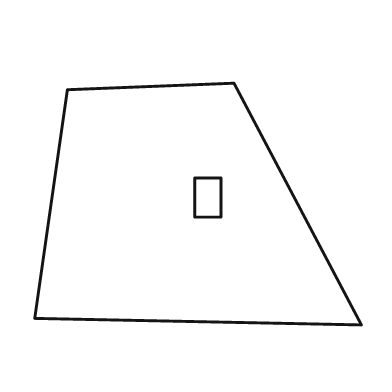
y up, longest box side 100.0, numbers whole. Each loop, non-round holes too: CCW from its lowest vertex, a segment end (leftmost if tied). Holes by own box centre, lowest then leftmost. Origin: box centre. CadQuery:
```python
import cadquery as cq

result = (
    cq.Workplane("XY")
    .moveTo(50.0, -37.0)
    .lineTo(11.0, 37.0)
    .lineTo(-40.0, 35.0)
    .lineTo(-50.0, -35.0)
    .close()
    .moveTo(-1.0, -4.0)
    .lineTo(7.0, -4.0)
    .lineTo(7.0, 8.0)
    .lineTo(-1.0, 8.0)
    .close()
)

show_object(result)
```